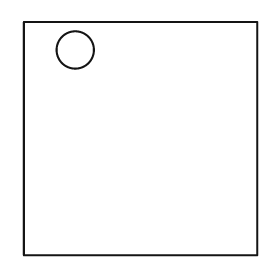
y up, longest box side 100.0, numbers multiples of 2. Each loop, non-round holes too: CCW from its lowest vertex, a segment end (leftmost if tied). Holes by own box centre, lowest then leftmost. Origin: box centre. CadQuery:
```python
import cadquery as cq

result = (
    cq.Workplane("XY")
    .moveTo(-50.0, -50.0)
    .lineTo(50.0, -50.0)
    .lineTo(50.0, 50.0)
    .lineTo(-50.0, 50.0)
    .close()
    .moveTo(-28.0, 38.0)
    .circle(8.0)
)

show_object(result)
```